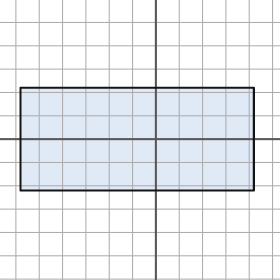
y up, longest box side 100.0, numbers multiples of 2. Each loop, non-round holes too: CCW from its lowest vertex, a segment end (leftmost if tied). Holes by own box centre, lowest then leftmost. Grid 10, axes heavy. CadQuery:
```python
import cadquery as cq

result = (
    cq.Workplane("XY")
    .moveTo(-58.0, -22.0)
    .lineTo(42.0, -22.0)
    .lineTo(42.0, 22.0)
    .lineTo(-58.0, 22.0)
    .close()
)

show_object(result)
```